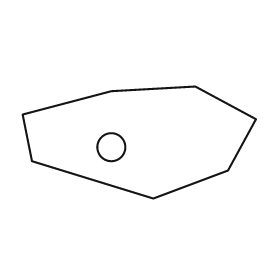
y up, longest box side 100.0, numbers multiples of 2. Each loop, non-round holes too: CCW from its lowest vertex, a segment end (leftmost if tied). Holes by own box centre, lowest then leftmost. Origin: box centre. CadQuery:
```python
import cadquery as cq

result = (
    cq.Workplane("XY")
    .moveTo(6.0, -24.0)
    .lineTo(38.0, -12.0)
    .lineTo(50.0, 10.0)
    .lineTo(24.0, 24.0)
    .lineTo(-12.0, 22.0)
    .lineTo(-50.0, 12.0)
    .lineTo(-46.0, -8.0)
    .close()
    .moveTo(-12.0, -2.0)
    .circle(6.0)
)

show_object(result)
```